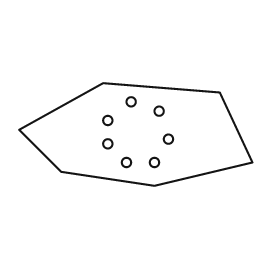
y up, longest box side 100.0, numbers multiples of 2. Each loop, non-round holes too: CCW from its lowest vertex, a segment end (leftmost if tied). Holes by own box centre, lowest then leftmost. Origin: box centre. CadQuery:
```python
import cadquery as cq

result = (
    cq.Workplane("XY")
    .moveTo(8.0, -22.0)
    .lineTo(50.0, -12.0)
    .lineTo(36.0, 18.0)
    .lineTo(-14.0, 22.0)
    .lineTo(-50.0, 2.0)
    .lineTo(-32.0, -16.0)
    .close()
    .moveTo(-4.0, -12.0)
    .circle(2.0)
    .moveTo(8.0, -12.0)
    .circle(2.0)
    .moveTo(-12.0, -4.0)
    .circle(2.0)
    .moveTo(14.0, -2.0)
    .circle(2.0)
    .moveTo(-12.0, 6.0)
    .circle(2.0)
    .moveTo(10.0, 10.0)
    .circle(2.0)
    .moveTo(-2.0, 14.0)
    .circle(2.0)
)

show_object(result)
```